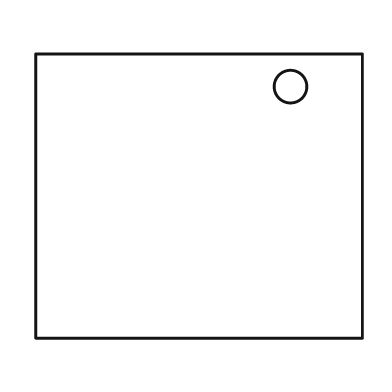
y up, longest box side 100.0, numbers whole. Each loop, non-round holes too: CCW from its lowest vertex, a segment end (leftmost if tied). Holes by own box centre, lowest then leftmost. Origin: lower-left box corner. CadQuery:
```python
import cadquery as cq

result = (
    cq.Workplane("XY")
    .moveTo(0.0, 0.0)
    .lineTo(100.0, 0.0)
    .lineTo(100.0, 87.0)
    .lineTo(0.0, 87.0)
    .close()
    .moveTo(78.0, 77.0)
    .circle(5.0)
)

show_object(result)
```